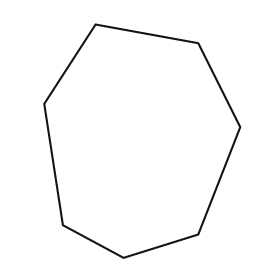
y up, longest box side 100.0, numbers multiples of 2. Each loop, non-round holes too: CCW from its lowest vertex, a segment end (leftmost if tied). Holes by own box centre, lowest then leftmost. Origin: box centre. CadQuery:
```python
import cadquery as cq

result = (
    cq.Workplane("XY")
    .moveTo(-8.0, -50.0)
    .lineTo(24.0, -40.0)
    .lineTo(42.0, 6.0)
    .lineTo(24.0, 42.0)
    .lineTo(-20.0, 50.0)
    .lineTo(-42.0, 16.0)
    .lineTo(-34.0, -36.0)
    .close()
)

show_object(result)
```